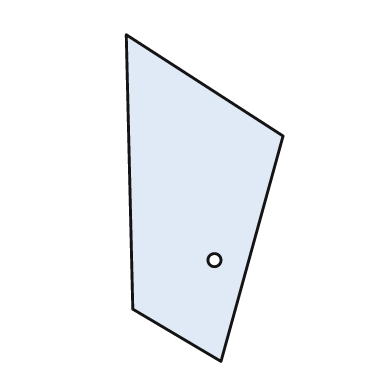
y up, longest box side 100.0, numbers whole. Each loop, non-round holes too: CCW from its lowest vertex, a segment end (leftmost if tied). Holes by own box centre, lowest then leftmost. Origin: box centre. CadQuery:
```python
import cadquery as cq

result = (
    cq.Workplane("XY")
    .moveTo(5.0, -50.0)
    .lineTo(24.0, 19.0)
    .lineTo(-24.0, 50.0)
    .lineTo(-22.0, -34.0)
    .close()
    .moveTo(3.0, -19.0)
    .circle(2.0)
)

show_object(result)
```